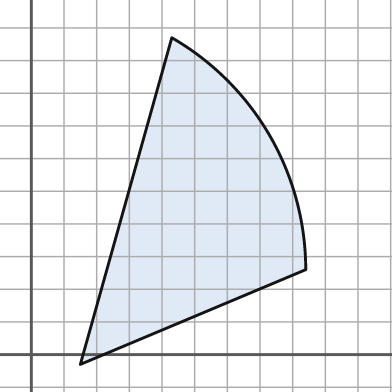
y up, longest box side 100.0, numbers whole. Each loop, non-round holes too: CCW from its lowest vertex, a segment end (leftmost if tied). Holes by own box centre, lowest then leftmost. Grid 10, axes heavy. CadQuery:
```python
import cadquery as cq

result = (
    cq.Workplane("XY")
    .moveTo(15.0, -3.0)
    .lineTo(84.0, 26.0)
    .threePointArc((73.0, 67.0), (43.0, 97.0))
    .close()
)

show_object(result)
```